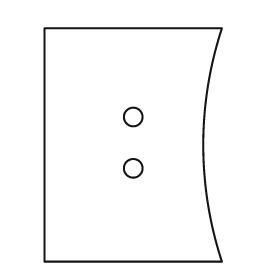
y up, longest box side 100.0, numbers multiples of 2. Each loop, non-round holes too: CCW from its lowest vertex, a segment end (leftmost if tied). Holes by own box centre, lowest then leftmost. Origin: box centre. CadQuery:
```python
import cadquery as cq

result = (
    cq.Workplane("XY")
    .moveTo(-38.0, -50.0)
    .lineTo(38.0, -50.0)
    .threePointArc((30.0, 0.0), (38.0, 50.0))
    .lineTo(-38.0, 50.0)
    .close()
    .moveTo(0.0, -10.0)
    .circle(4.0)
    .moveTo(0.0, 12.0)
    .circle(4.0)
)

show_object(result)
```